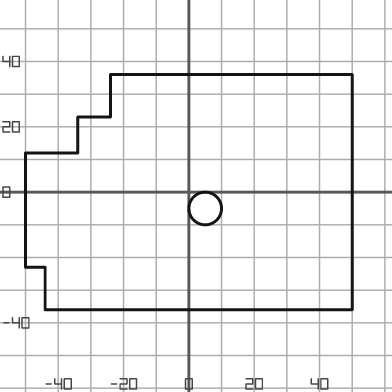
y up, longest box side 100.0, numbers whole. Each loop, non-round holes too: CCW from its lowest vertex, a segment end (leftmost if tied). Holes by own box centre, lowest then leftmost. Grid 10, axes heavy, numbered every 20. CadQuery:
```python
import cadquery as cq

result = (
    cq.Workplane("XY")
    .moveTo(-44.0, -36.0)
    .lineTo(50.0, -36.0)
    .lineTo(50.0, 36.0)
    .lineTo(-24.0, 36.0)
    .lineTo(-24.0, 23.0)
    .lineTo(-34.0, 23.0)
    .lineTo(-34.0, 12.0)
    .lineTo(-50.0, 12.0)
    .lineTo(-50.0, -23.0)
    .lineTo(-44.0, -23.0)
    .close()
    .moveTo(5.0, -5.0)
    .circle(5.0)
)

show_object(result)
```